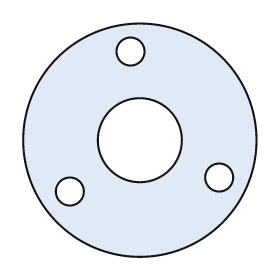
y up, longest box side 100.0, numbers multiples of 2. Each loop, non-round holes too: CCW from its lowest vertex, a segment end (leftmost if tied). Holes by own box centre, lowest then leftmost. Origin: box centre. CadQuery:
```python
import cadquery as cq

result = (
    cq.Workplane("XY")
    .moveTo(0.0, 0.0)
    .circle(50.0)
    .moveTo(-30.0, -22.0)
    .circle(6.0)
    .moveTo(34.0, -16.0)
    .circle(6.0)
    .moveTo(0.0, 0.0)
    .circle(18.0)
    .moveTo(-4.0, 38.0)
    .circle(6.0)
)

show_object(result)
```